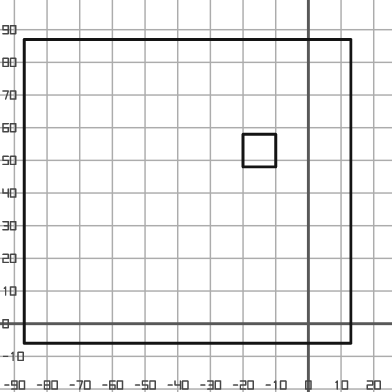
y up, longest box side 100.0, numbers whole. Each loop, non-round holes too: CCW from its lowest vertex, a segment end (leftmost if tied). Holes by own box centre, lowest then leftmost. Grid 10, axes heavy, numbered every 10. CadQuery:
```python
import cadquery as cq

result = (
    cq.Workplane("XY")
    .moveTo(-87.0, -6.0)
    .lineTo(13.0, -6.0)
    .lineTo(13.0, 87.0)
    .lineTo(-87.0, 87.0)
    .close()
    .moveTo(-20.0, 48.0)
    .lineTo(-10.0, 48.0)
    .lineTo(-10.0, 58.0)
    .lineTo(-20.0, 58.0)
    .close()
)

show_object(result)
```